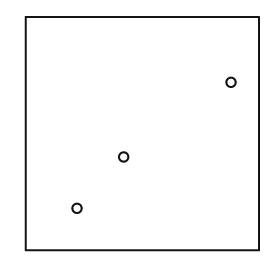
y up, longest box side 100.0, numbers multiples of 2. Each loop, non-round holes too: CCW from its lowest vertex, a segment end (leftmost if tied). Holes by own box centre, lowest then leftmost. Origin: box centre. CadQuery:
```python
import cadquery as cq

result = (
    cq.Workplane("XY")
    .moveTo(-50.0, -50.0)
    .lineTo(50.0, -50.0)
    .lineTo(50.0, 50.0)
    .lineTo(-50.0, 50.0)
    .close()
    .moveTo(-28.0, -32.0)
    .circle(2.0)
    .moveTo(-8.0, -10.0)
    .circle(2.0)
    .moveTo(38.0, 22.0)
    .circle(2.0)
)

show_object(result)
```